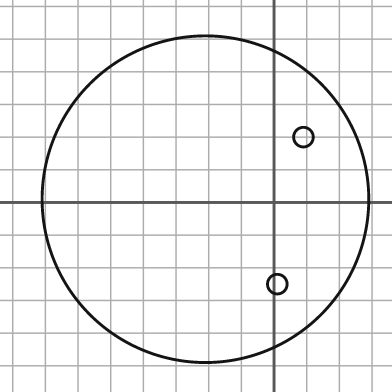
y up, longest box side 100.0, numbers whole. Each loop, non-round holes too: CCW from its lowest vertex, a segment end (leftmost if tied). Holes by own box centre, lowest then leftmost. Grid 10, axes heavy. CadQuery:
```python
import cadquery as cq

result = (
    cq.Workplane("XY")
    .moveTo(-21.0, 1.0)
    .circle(50.0)
    .moveTo(1.0, -25.0)
    .circle(3.0)
    .moveTo(9.0, 20.0)
    .circle(3.0)
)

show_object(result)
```